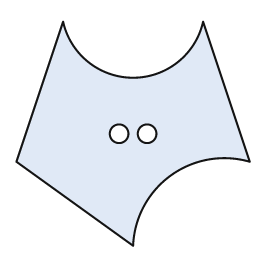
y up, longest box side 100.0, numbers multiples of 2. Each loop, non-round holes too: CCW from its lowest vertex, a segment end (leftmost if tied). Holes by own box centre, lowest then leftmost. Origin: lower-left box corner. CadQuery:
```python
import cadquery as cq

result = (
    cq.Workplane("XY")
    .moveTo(50.0, 0.0)
    .threePointArc((66.0, 30.0), (100.0, 36.0))
    .lineTo(80.0, 96.0)
    .threePointArc((50.0, 72.0), (20.0, 96.0))
    .lineTo(0.0, 36.0)
    .close()
    .moveTo(44.0, 48.0)
    .circle(4.0)
    .moveTo(56.0, 48.0)
    .circle(4.0)
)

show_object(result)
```